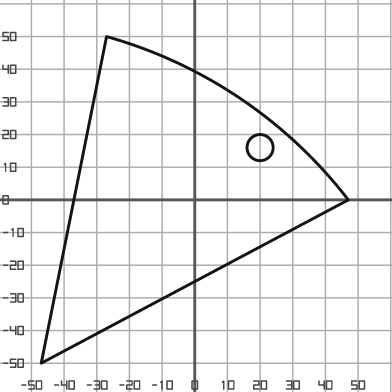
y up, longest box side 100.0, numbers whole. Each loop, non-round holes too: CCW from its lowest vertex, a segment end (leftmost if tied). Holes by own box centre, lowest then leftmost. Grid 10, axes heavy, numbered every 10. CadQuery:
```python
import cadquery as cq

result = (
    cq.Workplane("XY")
    .moveTo(-47.0, -50.0)
    .lineTo(47.0, 0.0)
    .threePointArc((14.0, 31.0), (-27.0, 50.0))
    .close()
    .moveTo(20.0, 16.0)
    .circle(4.0)
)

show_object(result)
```